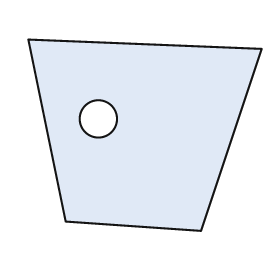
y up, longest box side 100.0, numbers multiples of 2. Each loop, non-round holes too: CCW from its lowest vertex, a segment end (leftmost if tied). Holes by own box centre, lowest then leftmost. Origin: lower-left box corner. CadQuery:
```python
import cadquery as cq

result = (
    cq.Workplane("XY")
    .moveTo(74.0, 0.0)
    .lineTo(100.0, 78.0)
    .lineTo(0.0, 82.0)
    .lineTo(16.0, 4.0)
    .close()
    .moveTo(30.0, 48.0)
    .circle(8.0)
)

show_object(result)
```